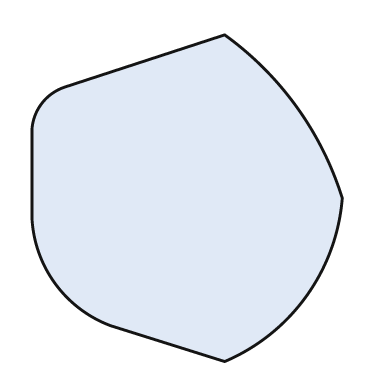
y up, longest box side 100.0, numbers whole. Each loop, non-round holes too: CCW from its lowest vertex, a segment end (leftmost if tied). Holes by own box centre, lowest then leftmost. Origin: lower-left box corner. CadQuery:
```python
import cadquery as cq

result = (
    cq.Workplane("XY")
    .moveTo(59.0, 0.0)
    .threePointArc((84.0, 20.0), (95.0, 50.0))
    .threePointArc((81.0, 78.0), (59.0, 100.0))
    .lineTo(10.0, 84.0)
    .threePointArc((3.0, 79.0), (0.0, 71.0))
    .lineTo(0.0, 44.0)
    .threePointArc((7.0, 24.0), (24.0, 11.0))
    .close()
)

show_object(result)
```